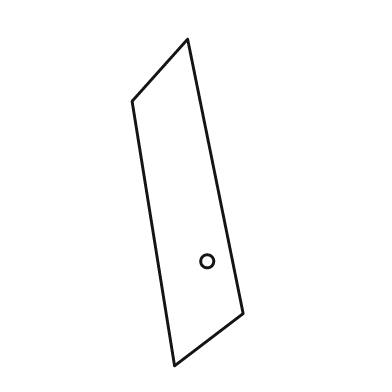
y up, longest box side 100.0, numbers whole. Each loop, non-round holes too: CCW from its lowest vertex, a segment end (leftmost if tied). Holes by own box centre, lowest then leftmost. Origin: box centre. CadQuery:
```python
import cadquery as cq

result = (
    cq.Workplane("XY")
    .moveTo(-4.0, -50.0)
    .lineTo(17.0, -34.0)
    .lineTo(0.0, 50.0)
    .lineTo(-17.0, 31.0)
    .close()
    .moveTo(6.0, -18.0)
    .circle(2.0)
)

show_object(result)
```